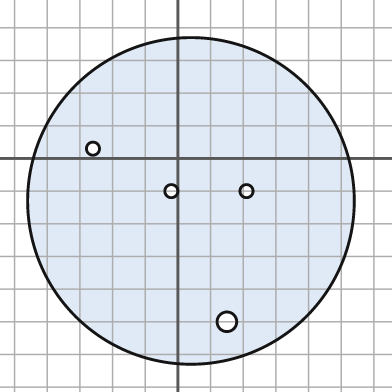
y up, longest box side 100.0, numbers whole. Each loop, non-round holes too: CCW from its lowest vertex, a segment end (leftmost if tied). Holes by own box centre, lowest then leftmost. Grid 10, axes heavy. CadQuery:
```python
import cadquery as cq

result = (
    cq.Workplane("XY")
    .moveTo(4.0, -13.0)
    .circle(50.0)
    .moveTo(15.0, -50.0)
    .circle(3.0)
    .moveTo(-2.0, -10.0)
    .circle(2.0)
    .moveTo(21.0, -10.0)
    .circle(2.0)
    .moveTo(-26.0, 3.0)
    .circle(2.0)
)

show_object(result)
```